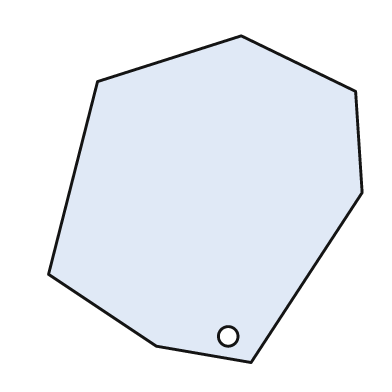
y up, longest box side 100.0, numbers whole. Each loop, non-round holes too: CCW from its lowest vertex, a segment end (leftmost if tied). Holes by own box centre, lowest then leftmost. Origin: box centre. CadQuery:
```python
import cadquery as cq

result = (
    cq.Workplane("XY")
    .moveTo(14.0, -50.0)
    .lineTo(48.0, 2.0)
    .lineTo(46.0, 33.0)
    .lineTo(11.0, 50.0)
    .lineTo(-33.0, 36.0)
    .lineTo(-48.0, -23.0)
    .lineTo(-15.0, -45.0)
    .close()
    .moveTo(7.0, -42.0)
    .circle(3.0)
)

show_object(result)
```